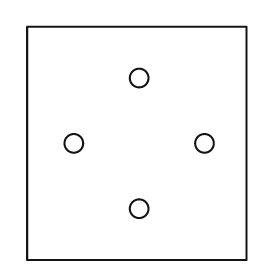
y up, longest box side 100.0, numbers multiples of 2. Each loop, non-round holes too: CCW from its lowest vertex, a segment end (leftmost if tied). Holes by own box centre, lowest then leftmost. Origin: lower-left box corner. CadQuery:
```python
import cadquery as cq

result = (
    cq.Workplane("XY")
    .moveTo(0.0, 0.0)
    .lineTo(94.0, 0.0)
    .lineTo(94.0, 100.0)
    .lineTo(0.0, 100.0)
    .close()
    .moveTo(48.0, 22.0)
    .circle(4.0)
    .moveTo(20.0, 50.0)
    .circle(4.0)
    .moveTo(76.0, 50.0)
    .circle(4.0)
    .moveTo(48.0, 78.0)
    .circle(4.0)
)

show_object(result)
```